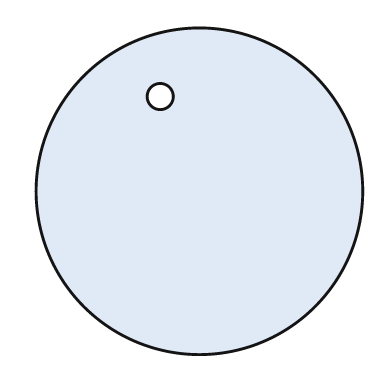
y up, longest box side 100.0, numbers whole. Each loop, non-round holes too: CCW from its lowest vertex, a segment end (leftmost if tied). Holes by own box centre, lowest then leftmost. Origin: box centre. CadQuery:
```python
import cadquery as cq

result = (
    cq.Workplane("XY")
    .moveTo(0.0, 0.0)
    .circle(50.0)
    .moveTo(-12.0, 29.0)
    .circle(4.0)
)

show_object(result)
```